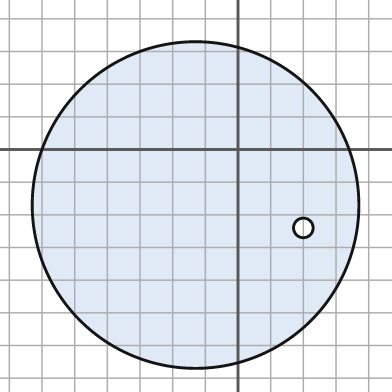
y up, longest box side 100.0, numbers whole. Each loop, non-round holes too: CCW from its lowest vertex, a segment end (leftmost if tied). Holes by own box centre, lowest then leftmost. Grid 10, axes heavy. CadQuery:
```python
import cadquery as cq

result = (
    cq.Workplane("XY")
    .moveTo(-13.0, -17.0)
    .circle(50.0)
    .moveTo(20.0, -24.0)
    .circle(3.0)
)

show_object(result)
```